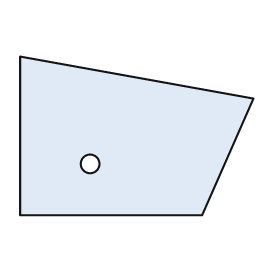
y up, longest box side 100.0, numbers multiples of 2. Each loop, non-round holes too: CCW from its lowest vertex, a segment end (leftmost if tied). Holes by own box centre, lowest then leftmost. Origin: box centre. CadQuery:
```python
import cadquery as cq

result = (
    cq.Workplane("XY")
    .moveTo(-50.0, -34.0)
    .lineTo(28.0, -34.0)
    .lineTo(50.0, 16.0)
    .lineTo(-50.0, 34.0)
    .close()
    .moveTo(-20.0, -12.0)
    .circle(4.0)
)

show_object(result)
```